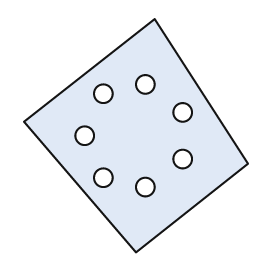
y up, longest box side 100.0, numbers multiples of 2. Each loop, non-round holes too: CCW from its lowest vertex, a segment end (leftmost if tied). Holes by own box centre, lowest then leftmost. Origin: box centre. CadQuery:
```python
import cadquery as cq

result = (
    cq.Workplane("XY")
    .moveTo(0.0, -50.0)
    .lineTo(48.0, -12.0)
    .lineTo(8.0, 50.0)
    .lineTo(-48.0, 6.0)
    .close()
    .moveTo(4.0, -22.0)
    .circle(4.0)
    .moveTo(-14.0, -18.0)
    .circle(4.0)
    .moveTo(20.0, -10.0)
    .circle(4.0)
    .moveTo(-22.0, 0.0)
    .circle(4.0)
    .moveTo(20.0, 10.0)
    .circle(4.0)
    .moveTo(-14.0, 18.0)
    .circle(4.0)
    .moveTo(4.0, 22.0)
    .circle(4.0)
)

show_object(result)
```